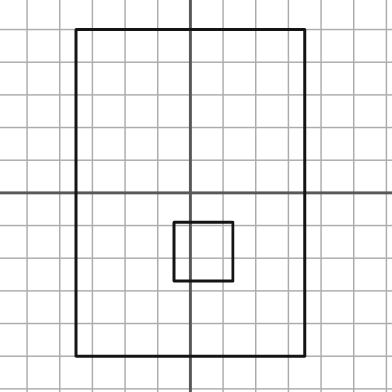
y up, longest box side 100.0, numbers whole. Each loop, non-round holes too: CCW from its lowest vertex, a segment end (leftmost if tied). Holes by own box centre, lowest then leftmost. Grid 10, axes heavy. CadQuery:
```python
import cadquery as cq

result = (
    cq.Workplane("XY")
    .moveTo(-35.0, -50.0)
    .lineTo(35.0, -50.0)
    .lineTo(35.0, 50.0)
    .lineTo(-35.0, 50.0)
    .close()
    .moveTo(-5.0, -27.0)
    .lineTo(13.0, -27.0)
    .lineTo(13.0, -9.0)
    .lineTo(-5.0, -9.0)
    .close()
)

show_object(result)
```